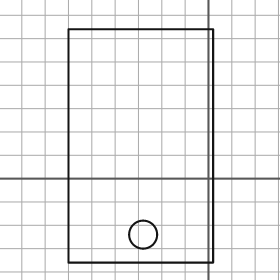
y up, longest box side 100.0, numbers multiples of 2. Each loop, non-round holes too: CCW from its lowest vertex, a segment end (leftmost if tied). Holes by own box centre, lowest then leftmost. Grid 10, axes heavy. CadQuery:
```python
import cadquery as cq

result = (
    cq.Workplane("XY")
    .moveTo(-60.0, -36.0)
    .lineTo(2.0, -36.0)
    .lineTo(2.0, 64.0)
    .lineTo(-60.0, 64.0)
    .close()
    .moveTo(-28.0, -24.0)
    .circle(6.0)
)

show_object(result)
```